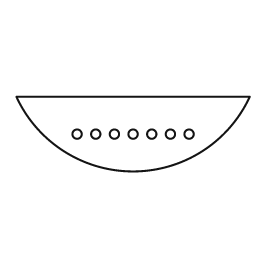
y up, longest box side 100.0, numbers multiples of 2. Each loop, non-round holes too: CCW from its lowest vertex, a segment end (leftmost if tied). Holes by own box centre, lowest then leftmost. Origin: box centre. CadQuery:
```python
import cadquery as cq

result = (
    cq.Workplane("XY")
    .moveTo(-50.0, 16.0)
    .threePointArc((0.0, -16.0), (50.0, 16.0))
    .close()
    .moveTo(-24.0, 0.0)
    .circle(2.0)
    .moveTo(-16.0, 0.0)
    .circle(2.0)
    .moveTo(-8.0, 0.0)
    .circle(2.0)
    .moveTo(0.0, 0.0)
    .circle(2.0)
    .moveTo(8.0, 0.0)
    .circle(2.0)
    .moveTo(16.0, 0.0)
    .circle(2.0)
    .moveTo(24.0, 0.0)
    .circle(2.0)
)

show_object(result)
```